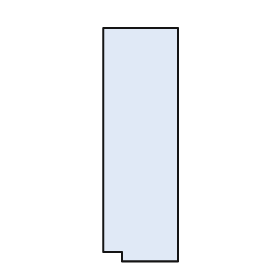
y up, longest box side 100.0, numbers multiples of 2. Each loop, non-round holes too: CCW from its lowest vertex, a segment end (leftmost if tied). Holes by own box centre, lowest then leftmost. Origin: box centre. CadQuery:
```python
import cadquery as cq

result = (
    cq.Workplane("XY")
    .moveTo(-8.0, -50.0)
    .lineTo(16.0, -50.0)
    .lineTo(16.0, 50.0)
    .lineTo(-16.0, 50.0)
    .lineTo(-16.0, -46.0)
    .lineTo(-8.0, -46.0)
    .close()
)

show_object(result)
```